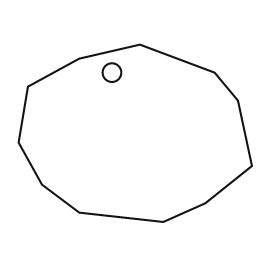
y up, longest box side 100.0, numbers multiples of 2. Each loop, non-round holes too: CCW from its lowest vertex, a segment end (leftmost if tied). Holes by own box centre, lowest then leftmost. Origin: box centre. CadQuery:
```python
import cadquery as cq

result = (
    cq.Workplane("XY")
    .moveTo(12.0, -38.0)
    .lineTo(30.0, -30.0)
    .lineTo(50.0, -14.0)
    .lineTo(44.0, 14.0)
    .lineTo(34.0, 26.0)
    .lineTo(2.0, 38.0)
    .lineTo(-24.0, 32.0)
    .lineTo(-46.0, 20.0)
    .lineTo(-50.0, -4.0)
    .lineTo(-40.0, -22.0)
    .lineTo(-24.0, -34.0)
    .close()
    .moveTo(-10.0, 26.0)
    .circle(4.0)
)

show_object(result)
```